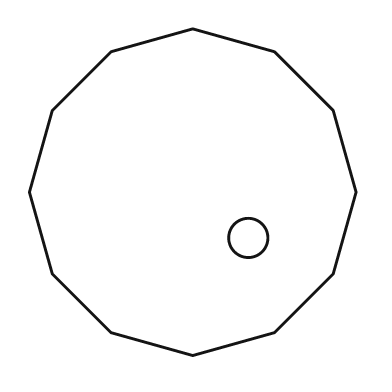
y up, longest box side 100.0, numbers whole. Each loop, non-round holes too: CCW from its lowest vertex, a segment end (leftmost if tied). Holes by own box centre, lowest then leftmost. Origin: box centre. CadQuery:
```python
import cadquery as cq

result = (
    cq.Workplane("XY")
    .moveTo(0.0, -50.0)
    .lineTo(25.0, -43.0)
    .lineTo(43.0, -25.0)
    .lineTo(50.0, 0.0)
    .lineTo(43.0, 25.0)
    .lineTo(25.0, 43.0)
    .lineTo(0.0, 50.0)
    .lineTo(-25.0, 43.0)
    .lineTo(-43.0, 25.0)
    .lineTo(-50.0, 0.0)
    .lineTo(-43.0, -25.0)
    .lineTo(-25.0, -43.0)
    .close()
    .moveTo(17.0, -14.0)
    .circle(6.0)
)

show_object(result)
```